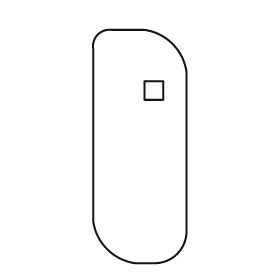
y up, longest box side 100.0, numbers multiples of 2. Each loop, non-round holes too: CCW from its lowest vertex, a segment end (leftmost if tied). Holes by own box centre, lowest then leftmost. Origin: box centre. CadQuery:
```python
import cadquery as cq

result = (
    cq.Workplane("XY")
    .moveTo(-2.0, -50.0)
    .lineTo(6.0, -50.0)
    .threePointArc((16.0, -46.0), (20.0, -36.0))
    .lineTo(20.0, 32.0)
    .threePointArc((14.0, 44.0), (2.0, 50.0))
    .lineTo(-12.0, 50.0)
    .threePointArc((-18.0, 48.0), (-20.0, 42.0))
    .lineTo(-20.0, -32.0)
    .threePointArc((-14.0, -44.0), (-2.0, -50.0))
    .close()
    .moveTo(2.0, 20.0)
    .lineTo(10.0, 20.0)
    .lineTo(10.0, 28.0)
    .lineTo(2.0, 28.0)
    .close()
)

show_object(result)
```